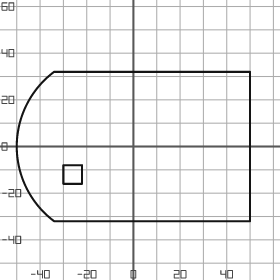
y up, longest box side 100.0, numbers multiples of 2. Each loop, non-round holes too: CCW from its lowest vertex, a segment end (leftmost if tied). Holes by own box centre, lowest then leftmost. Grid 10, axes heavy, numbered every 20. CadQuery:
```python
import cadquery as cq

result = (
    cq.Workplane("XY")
    .moveTo(-34.0, -32.0)
    .lineTo(50.0, -32.0)
    .lineTo(50.0, 32.0)
    .lineTo(-34.0, 32.0)
    .threePointArc((-50.0, 0.0), (-34.0, -32.0))
    .close()
    .moveTo(-30.0, -16.0)
    .lineTo(-22.0, -16.0)
    .lineTo(-22.0, -8.0)
    .lineTo(-30.0, -8.0)
    .close()
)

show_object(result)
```